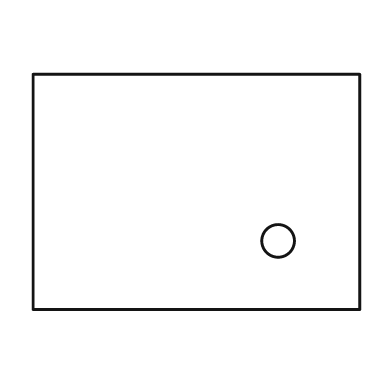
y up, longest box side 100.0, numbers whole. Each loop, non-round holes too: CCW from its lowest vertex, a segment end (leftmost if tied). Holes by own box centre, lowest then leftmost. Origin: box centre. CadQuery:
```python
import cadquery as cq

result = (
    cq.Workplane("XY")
    .moveTo(-50.0, -36.0)
    .lineTo(50.0, -36.0)
    .lineTo(50.0, 36.0)
    .lineTo(-50.0, 36.0)
    .close()
    .moveTo(25.0, -15.0)
    .circle(5.0)
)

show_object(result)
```